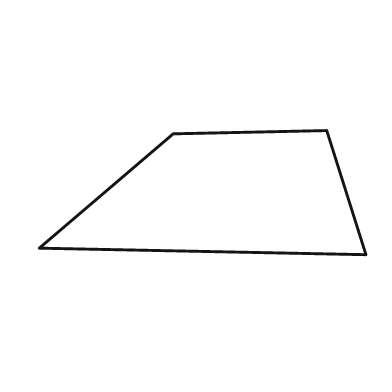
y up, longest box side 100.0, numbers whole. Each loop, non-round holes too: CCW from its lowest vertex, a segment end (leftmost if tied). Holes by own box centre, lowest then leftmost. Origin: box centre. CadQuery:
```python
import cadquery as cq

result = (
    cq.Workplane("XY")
    .moveTo(50.0, -19.0)
    .lineTo(38.0, 19.0)
    .lineTo(-9.0, 18.0)
    .lineTo(-50.0, -17.0)
    .close()
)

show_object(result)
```